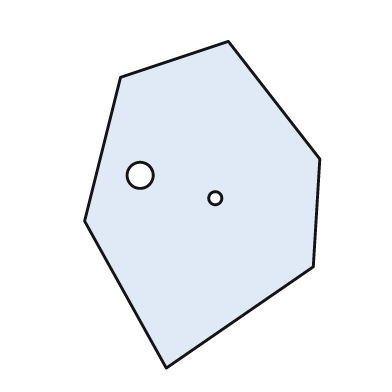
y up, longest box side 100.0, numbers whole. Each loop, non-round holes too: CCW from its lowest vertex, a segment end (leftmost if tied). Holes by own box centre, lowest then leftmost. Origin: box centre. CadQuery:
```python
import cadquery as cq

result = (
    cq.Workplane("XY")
    .moveTo(-11.0, -50.0)
    .lineTo(34.0, -19.0)
    .lineTo(36.0, 14.0)
    .lineTo(8.0, 50.0)
    .lineTo(-25.0, 39.0)
    .lineTo(-36.0, -5.0)
    .close()
    .moveTo(4.0, 2.0)
    .circle(2.0)
    .moveTo(-19.0, 9.0)
    .circle(4.0)
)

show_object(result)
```